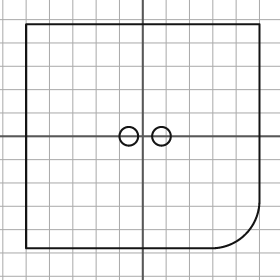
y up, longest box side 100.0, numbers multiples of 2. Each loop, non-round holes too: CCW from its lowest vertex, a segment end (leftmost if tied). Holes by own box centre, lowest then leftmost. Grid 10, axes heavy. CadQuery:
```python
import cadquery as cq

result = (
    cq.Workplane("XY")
    .moveTo(-50.0, -48.0)
    .lineTo(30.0, -48.0)
    .threePointArc((44.0, -42.0), (50.0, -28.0))
    .lineTo(50.0, 48.0)
    .lineTo(-50.0, 48.0)
    .close()
    .moveTo(-6.0, 0.0)
    .circle(4.0)
    .moveTo(8.0, 0.0)
    .circle(4.0)
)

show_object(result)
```